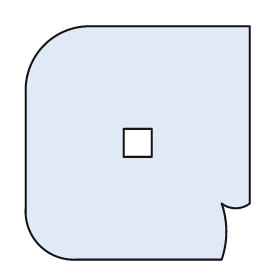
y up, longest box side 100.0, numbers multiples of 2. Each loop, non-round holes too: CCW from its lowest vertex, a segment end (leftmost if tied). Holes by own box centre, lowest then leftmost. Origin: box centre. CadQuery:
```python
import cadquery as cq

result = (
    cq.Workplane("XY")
    .moveTo(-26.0, -50.0)
    .lineTo(36.0, -50.0)
    .threePointArc((38.0, -38.0), (36.0, -26.0))
    .threePointArc((42.0, -28.0), (48.0, -26.0))
    .lineTo(48.0, 50.0)
    .lineTo(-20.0, 50.0)
    .threePointArc((-40.0, 42.0), (-48.0, 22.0))
    .lineTo(-48.0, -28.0)
    .threePointArc((-42.0, -44.0), (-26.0, -50.0))
    .close()
    .moveTo(-6.0, -6.0)
    .lineTo(6.0, -6.0)
    .lineTo(6.0, 6.0)
    .lineTo(-6.0, 6.0)
    .close()
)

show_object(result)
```